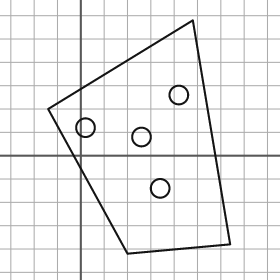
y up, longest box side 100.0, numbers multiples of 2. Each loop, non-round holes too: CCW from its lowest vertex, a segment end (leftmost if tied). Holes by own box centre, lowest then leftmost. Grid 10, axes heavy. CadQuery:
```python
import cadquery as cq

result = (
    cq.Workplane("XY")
    .moveTo(20.0, -42.0)
    .lineTo(64.0, -38.0)
    .lineTo(48.0, 58.0)
    .lineTo(-14.0, 20.0)
    .close()
    .moveTo(34.0, -14.0)
    .circle(4.0)
    .moveTo(26.0, 8.0)
    .circle(4.0)
    .moveTo(2.0, 12.0)
    .circle(4.0)
    .moveTo(42.0, 26.0)
    .circle(4.0)
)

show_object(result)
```